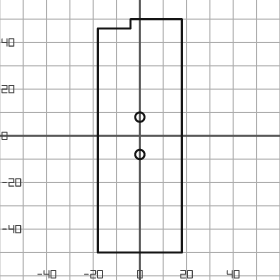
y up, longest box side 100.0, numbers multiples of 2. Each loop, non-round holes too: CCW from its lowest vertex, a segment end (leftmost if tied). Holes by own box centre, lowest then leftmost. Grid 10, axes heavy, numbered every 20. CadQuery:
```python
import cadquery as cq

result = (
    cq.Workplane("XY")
    .moveTo(-18.0, -50.0)
    .lineTo(18.0, -50.0)
    .lineTo(18.0, 50.0)
    .lineTo(-4.0, 50.0)
    .lineTo(-4.0, 46.0)
    .lineTo(-18.0, 46.0)
    .close()
    .moveTo(0.0, -8.0)
    .circle(2.0)
    .moveTo(0.0, 8.0)
    .circle(2.0)
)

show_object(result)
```